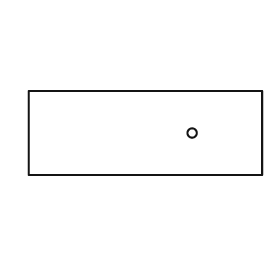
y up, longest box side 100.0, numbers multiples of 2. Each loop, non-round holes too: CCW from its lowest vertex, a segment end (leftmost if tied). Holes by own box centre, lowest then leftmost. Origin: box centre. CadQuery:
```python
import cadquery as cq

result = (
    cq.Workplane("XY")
    .moveTo(-50.0, -18.0)
    .lineTo(50.0, -18.0)
    .lineTo(50.0, 18.0)
    .lineTo(-50.0, 18.0)
    .close()
    .moveTo(20.0, 0.0)
    .circle(2.0)
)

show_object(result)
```